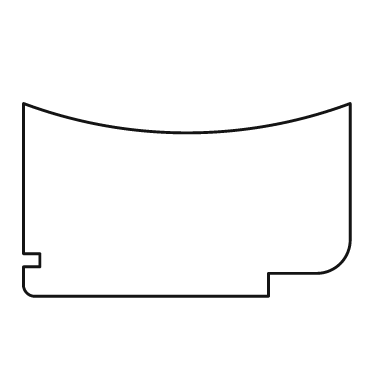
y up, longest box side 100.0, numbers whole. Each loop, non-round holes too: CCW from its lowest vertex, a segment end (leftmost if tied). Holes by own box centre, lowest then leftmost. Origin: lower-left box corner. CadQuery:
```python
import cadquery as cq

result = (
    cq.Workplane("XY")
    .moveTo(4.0, 0.0)
    .lineTo(75.0, 0.0)
    .lineTo(75.0, 7.0)
    .lineTo(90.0, 7.0)
    .threePointArc((97.0, 10.0), (100.0, 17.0))
    .lineTo(100.0, 59.0)
    .threePointArc((50.0, 50.0), (0.0, 59.0))
    .lineTo(0.0, 13.0)
    .lineTo(5.0, 13.0)
    .lineTo(5.0, 9.0)
    .lineTo(0.0, 9.0)
    .lineTo(0.0, 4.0)
    .threePointArc((1.0, 1.0), (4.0, 0.0))
    .close()
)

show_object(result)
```